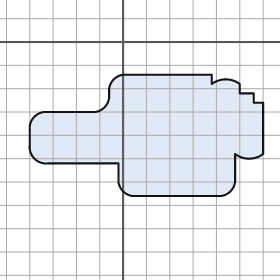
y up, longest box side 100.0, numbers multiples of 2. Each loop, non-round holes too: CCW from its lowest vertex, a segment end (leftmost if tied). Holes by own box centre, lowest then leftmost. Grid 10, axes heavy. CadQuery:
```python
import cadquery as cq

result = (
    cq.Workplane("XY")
    .moveTo(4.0, -66.0)
    .lineTo(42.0, -66.0)
    .threePointArc((46.0, -64.0), (48.0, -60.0))
    .lineTo(48.0, -48.0)
    .threePointArc((54.0, -50.0), (60.0, -48.0))
    .lineTo(60.0, -26.0)
    .lineTo(56.0, -26.0)
    .lineTo(56.0, -22.0)
    .lineTo(50.0, -22.0)
    .lineTo(50.0, -18.0)
    .threePointArc((44.0, -16.0), (38.0, -18.0))
    .lineTo(38.0, -14.0)
    .lineTo(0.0, -14.0)
    .threePointArc((-4.0, -16.0), (-6.0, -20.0))
    .lineTo(-6.0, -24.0)
    .threePointArc((-8.0, -28.0), (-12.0, -30.0))
    .lineTo(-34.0, -30.0)
    .threePointArc((-38.0, -32.0), (-40.0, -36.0))
    .lineTo(-40.0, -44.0)
    .threePointArc((-38.0, -50.0), (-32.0, -52.0))
    .lineTo(-2.0, -52.0)
    .lineTo(-2.0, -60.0)
    .threePointArc((0.0, -64.0), (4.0, -66.0))
    .close()
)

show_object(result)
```